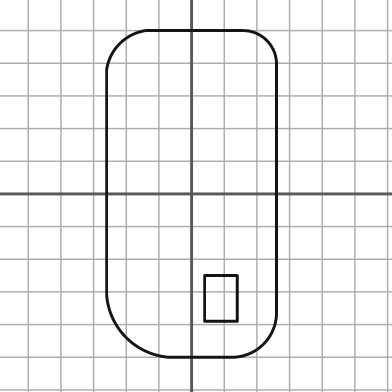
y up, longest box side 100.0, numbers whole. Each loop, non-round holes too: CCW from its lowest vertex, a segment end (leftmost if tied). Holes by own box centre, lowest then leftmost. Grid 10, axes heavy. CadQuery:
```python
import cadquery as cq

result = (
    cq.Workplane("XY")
    .moveTo(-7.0, -50.0)
    .lineTo(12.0, -50.0)
    .threePointArc((22.0, -46.0), (26.0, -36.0))
    .lineTo(26.0, 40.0)
    .threePointArc((23.0, 47.0), (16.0, 50.0))
    .lineTo(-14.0, 50.0)
    .threePointArc((-22.0, 46.0), (-26.0, 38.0))
    .lineTo(-26.0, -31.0)
    .threePointArc((-20.0, -44.0), (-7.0, -50.0))
    .close()
    .moveTo(4.0, -39.0)
    .lineTo(14.0, -39.0)
    .lineTo(14.0, -25.0)
    .lineTo(4.0, -25.0)
    .close()
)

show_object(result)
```